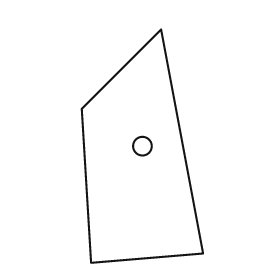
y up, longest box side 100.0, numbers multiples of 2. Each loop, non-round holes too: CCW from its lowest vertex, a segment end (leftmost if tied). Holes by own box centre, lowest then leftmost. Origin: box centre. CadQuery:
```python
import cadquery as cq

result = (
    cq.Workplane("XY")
    .moveTo(-22.0, -50.0)
    .lineTo(26.0, -46.0)
    .lineTo(8.0, 50.0)
    .lineTo(-26.0, 16.0)
    .close()
    .moveTo(0.0, 0.0)
    .circle(4.0)
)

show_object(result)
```